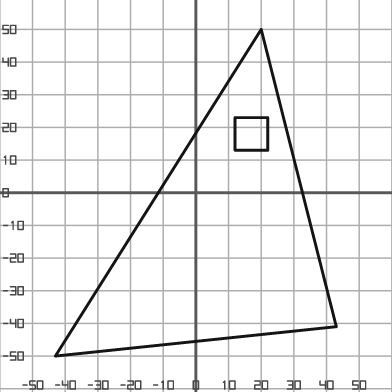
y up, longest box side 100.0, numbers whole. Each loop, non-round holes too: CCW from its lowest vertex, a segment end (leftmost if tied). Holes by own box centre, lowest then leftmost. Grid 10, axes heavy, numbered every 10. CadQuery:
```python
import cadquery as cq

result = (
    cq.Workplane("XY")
    .moveTo(-43.0, -50.0)
    .lineTo(43.0, -41.0)
    .lineTo(20.0, 50.0)
    .close()
    .moveTo(12.0, 13.0)
    .lineTo(22.0, 13.0)
    .lineTo(22.0, 23.0)
    .lineTo(12.0, 23.0)
    .close()
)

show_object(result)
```